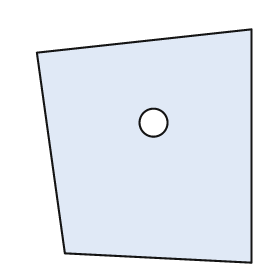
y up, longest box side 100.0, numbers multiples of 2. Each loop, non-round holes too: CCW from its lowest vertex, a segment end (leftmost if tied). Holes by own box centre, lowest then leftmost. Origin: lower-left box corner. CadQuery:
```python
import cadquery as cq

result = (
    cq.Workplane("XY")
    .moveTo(92.0, 0.0)
    .lineTo(92.0, 100.0)
    .lineTo(0.0, 90.0)
    .lineTo(12.0, 4.0)
    .close()
    .moveTo(50.0, 60.0)
    .circle(6.0)
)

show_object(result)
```